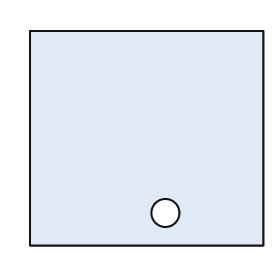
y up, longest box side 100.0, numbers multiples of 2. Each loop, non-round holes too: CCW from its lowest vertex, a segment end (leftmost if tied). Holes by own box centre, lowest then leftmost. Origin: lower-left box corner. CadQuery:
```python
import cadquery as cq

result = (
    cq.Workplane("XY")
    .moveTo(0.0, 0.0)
    .lineTo(100.0, 0.0)
    .lineTo(100.0, 92.0)
    .lineTo(0.0, 92.0)
    .close()
    .moveTo(58.0, 14.0)
    .circle(6.0)
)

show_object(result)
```